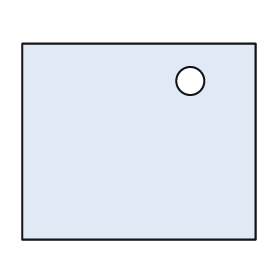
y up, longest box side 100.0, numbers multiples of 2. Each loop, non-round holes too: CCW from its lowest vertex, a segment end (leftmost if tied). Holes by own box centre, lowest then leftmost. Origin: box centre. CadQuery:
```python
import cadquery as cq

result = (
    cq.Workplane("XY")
    .moveTo(-50.0, -42.0)
    .lineTo(50.0, -42.0)
    .lineTo(50.0, 42.0)
    .lineTo(-50.0, 42.0)
    .close()
    .moveTo(22.0, 26.0)
    .circle(6.0)
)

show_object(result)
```